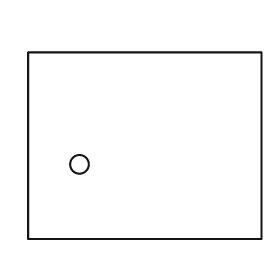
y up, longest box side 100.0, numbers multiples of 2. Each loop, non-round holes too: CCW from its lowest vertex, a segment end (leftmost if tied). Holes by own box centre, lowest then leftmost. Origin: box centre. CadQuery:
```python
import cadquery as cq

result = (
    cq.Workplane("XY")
    .moveTo(-50.0, -40.0)
    .lineTo(50.0, -40.0)
    .lineTo(50.0, 40.0)
    .lineTo(-50.0, 40.0)
    .close()
    .moveTo(-28.0, -8.0)
    .circle(4.0)
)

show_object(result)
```